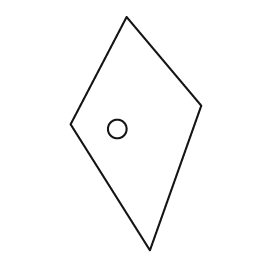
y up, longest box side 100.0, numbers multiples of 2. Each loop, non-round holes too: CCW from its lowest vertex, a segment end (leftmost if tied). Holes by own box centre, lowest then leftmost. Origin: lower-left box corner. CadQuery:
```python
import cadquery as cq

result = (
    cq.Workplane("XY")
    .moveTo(34.0, 0.0)
    .lineTo(56.0, 62.0)
    .lineTo(24.0, 100.0)
    .lineTo(0.0, 54.0)
    .close()
    .moveTo(20.0, 52.0)
    .circle(4.0)
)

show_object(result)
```